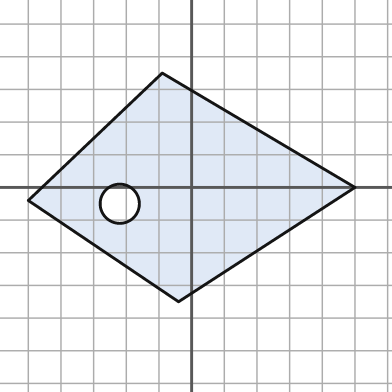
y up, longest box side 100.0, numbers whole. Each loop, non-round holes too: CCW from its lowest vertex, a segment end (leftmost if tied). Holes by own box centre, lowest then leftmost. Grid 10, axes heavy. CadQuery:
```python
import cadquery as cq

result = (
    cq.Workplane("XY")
    .moveTo(-4.0, -35.0)
    .lineTo(50.0, 0.0)
    .lineTo(-9.0, 35.0)
    .lineTo(-50.0, -4.0)
    .close()
    .moveTo(-22.0, -5.0)
    .circle(6.0)
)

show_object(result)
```